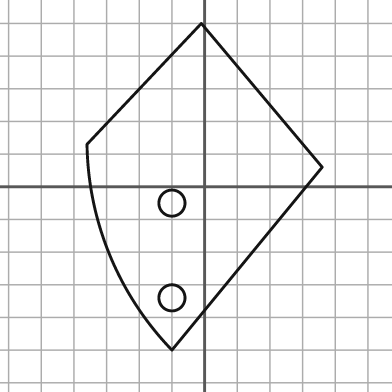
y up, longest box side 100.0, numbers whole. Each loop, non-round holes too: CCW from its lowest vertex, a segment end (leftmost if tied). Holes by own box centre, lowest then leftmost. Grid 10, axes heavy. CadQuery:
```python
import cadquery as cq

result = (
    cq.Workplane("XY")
    .moveTo(-10.0, -50.0)
    .lineTo(36.0, 6.0)
    .lineTo(-1.0, 50.0)
    .lineTo(-36.0, 13.0)
    .threePointArc((-29.0, -21.0), (-10.0, -50.0))
    .close()
    .moveTo(-10.0, -34.0)
    .circle(4.0)
    .moveTo(-10.0, -5.0)
    .circle(4.0)
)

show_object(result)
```